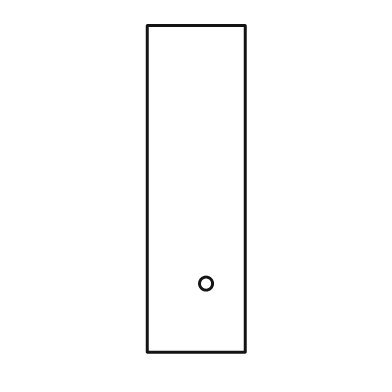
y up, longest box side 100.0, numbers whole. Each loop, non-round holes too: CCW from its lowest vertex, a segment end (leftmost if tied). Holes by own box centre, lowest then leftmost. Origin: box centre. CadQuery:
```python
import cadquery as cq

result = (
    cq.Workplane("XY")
    .moveTo(-15.0, -50.0)
    .lineTo(15.0, -50.0)
    .lineTo(15.0, 50.0)
    .lineTo(-15.0, 50.0)
    .close()
    .moveTo(3.0, -29.0)
    .circle(2.0)
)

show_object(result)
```